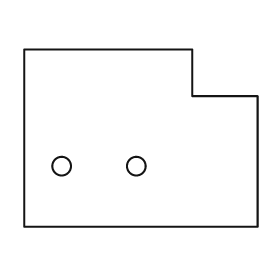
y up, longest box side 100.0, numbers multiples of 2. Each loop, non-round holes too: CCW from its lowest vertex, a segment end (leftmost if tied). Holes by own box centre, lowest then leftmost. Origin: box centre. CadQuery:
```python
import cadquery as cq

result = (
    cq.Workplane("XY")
    .moveTo(-50.0, -38.0)
    .lineTo(50.0, -38.0)
    .lineTo(50.0, 18.0)
    .lineTo(22.0, 18.0)
    .lineTo(22.0, 38.0)
    .lineTo(-50.0, 38.0)
    .close()
    .moveTo(-34.0, -12.0)
    .circle(4.0)
    .moveTo(-2.0, -12.0)
    .circle(4.0)
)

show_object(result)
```